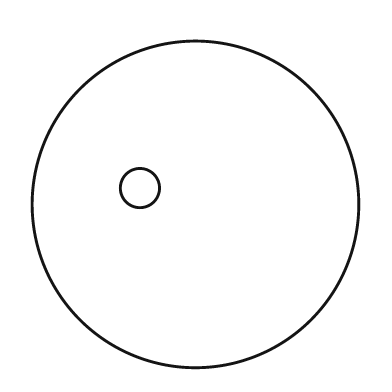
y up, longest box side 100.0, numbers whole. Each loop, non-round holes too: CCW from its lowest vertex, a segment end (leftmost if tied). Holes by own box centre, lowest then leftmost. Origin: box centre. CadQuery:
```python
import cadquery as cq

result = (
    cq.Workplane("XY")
    .moveTo(0.0, 0.0)
    .circle(50.0)
    .moveTo(-17.0, 5.0)
    .circle(6.0)
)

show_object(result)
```